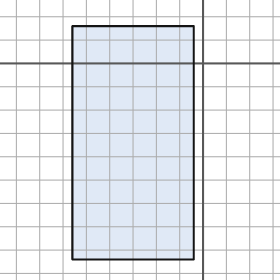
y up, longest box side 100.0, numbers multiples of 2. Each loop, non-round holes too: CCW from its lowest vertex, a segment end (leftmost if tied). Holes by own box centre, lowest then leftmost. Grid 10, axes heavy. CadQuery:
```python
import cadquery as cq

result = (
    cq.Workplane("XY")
    .moveTo(-56.0, -84.0)
    .lineTo(-4.0, -84.0)
    .lineTo(-4.0, 16.0)
    .lineTo(-56.0, 16.0)
    .close()
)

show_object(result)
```